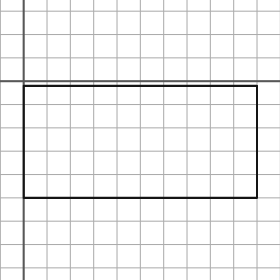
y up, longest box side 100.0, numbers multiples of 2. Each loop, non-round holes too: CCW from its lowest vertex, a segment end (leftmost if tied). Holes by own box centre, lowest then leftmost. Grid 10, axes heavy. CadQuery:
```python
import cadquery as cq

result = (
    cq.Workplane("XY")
    .moveTo(0.0, -50.0)
    .lineTo(100.0, -50.0)
    .lineTo(100.0, -2.0)
    .lineTo(0.0, -2.0)
    .close()
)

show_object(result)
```